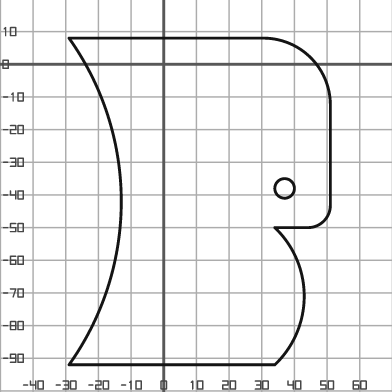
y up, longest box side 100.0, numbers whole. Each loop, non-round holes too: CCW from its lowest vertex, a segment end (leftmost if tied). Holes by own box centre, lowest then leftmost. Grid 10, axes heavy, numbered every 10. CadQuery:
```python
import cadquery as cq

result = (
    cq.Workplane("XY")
    .moveTo(-29.0, -92.0)
    .lineTo(34.0, -92.0)
    .threePointArc((43.0, -71.0), (34.0, -50.0))
    .lineTo(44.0, -50.0)
    .threePointArc((49.0, -48.0), (51.0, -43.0))
    .lineTo(51.0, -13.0)
    .threePointArc((45.0, 2.0), (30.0, 8.0))
    .lineTo(-29.0, 8.0)
    .threePointArc((-13.0, -42.0), (-29.0, -92.0))
    .close()
    .moveTo(37.0, -38.0)
    .circle(3.0)
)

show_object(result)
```